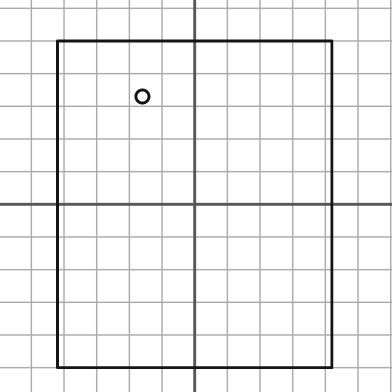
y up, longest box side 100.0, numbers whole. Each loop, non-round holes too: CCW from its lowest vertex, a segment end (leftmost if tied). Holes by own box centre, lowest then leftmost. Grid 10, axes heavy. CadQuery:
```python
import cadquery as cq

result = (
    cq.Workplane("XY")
    .moveTo(-42.0, -50.0)
    .lineTo(42.0, -50.0)
    .lineTo(42.0, 50.0)
    .lineTo(-42.0, 50.0)
    .close()
    .moveTo(-16.0, 33.0)
    .circle(2.0)
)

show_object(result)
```